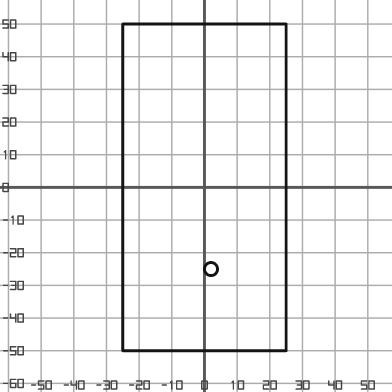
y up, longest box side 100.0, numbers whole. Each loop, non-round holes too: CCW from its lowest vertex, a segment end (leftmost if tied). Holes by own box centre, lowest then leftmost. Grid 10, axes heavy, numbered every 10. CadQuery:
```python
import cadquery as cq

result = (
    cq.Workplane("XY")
    .moveTo(-25.0, -50.0)
    .lineTo(25.0, -50.0)
    .lineTo(25.0, 50.0)
    .lineTo(-25.0, 50.0)
    .close()
    .moveTo(2.0, -25.0)
    .circle(2.0)
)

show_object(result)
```